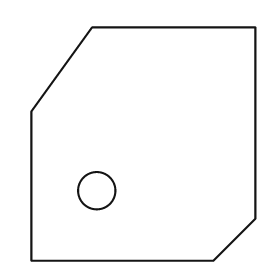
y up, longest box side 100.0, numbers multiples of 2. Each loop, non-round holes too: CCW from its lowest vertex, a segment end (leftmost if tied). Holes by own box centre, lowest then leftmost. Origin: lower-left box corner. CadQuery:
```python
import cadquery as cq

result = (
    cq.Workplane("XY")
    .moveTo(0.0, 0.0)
    .lineTo(78.0, 0.0)
    .lineTo(96.0, 18.0)
    .lineTo(96.0, 100.0)
    .lineTo(26.0, 100.0)
    .lineTo(0.0, 64.0)
    .close()
    .moveTo(28.0, 30.0)
    .circle(8.0)
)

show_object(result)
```